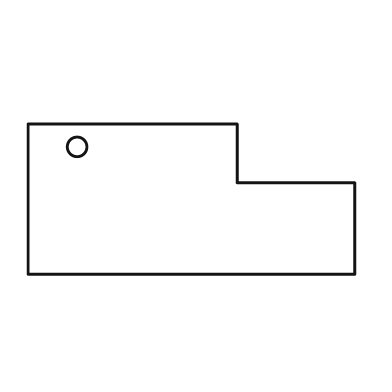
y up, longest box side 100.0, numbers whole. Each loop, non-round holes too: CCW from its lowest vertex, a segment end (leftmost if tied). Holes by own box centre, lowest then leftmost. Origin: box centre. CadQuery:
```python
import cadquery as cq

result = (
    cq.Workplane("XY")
    .moveTo(-50.0, -23.0)
    .lineTo(50.0, -23.0)
    .lineTo(50.0, 5.0)
    .lineTo(14.0, 5.0)
    .lineTo(14.0, 23.0)
    .lineTo(-50.0, 23.0)
    .close()
    .moveTo(-35.0, 16.0)
    .circle(3.0)
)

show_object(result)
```